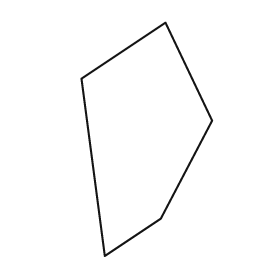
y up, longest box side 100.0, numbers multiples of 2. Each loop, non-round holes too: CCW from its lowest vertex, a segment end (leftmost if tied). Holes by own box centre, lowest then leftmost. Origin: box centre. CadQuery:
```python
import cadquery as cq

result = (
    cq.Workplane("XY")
    .moveTo(-18.0, -50.0)
    .lineTo(6.0, -34.0)
    .lineTo(28.0, 8.0)
    .lineTo(8.0, 50.0)
    .lineTo(-28.0, 26.0)
    .close()
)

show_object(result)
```